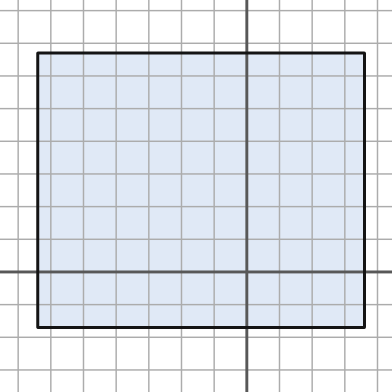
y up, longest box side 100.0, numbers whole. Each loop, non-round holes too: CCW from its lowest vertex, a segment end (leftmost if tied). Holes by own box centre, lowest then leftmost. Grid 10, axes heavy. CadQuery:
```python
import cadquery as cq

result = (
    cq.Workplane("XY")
    .moveTo(-64.0, -17.0)
    .lineTo(36.0, -17.0)
    .lineTo(36.0, 67.0)
    .lineTo(-64.0, 67.0)
    .close()
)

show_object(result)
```